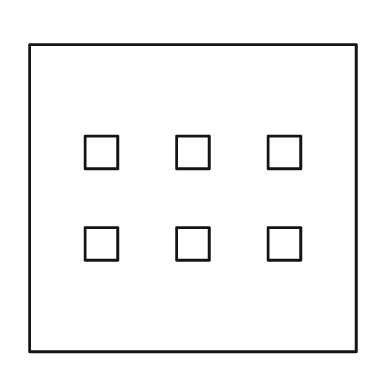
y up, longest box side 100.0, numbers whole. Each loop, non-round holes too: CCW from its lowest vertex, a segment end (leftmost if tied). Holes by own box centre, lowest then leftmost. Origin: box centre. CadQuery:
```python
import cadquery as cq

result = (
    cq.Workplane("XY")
    .moveTo(-50.0, -47.0)
    .lineTo(50.0, -47.0)
    .lineTo(50.0, 47.0)
    .lineTo(-50.0, 47.0)
    .close()
    .moveTo(-33.0, -19.0)
    .lineTo(-23.0, -19.0)
    .lineTo(-23.0, -9.0)
    .lineTo(-33.0, -9.0)
    .close()
    .moveTo(-5.0, -19.0)
    .lineTo(5.0, -19.0)
    .lineTo(5.0, -9.0)
    .lineTo(-5.0, -9.0)
    .close()
    .moveTo(23.0, -19.0)
    .lineTo(33.0, -19.0)
    .lineTo(33.0, -9.0)
    .lineTo(23.0, -9.0)
    .close()
    .moveTo(-33.0, 9.0)
    .lineTo(-23.0, 9.0)
    .lineTo(-23.0, 19.0)
    .lineTo(-33.0, 19.0)
    .close()
    .moveTo(-5.0, 9.0)
    .lineTo(5.0, 9.0)
    .lineTo(5.0, 19.0)
    .lineTo(-5.0, 19.0)
    .close()
    .moveTo(23.0, 9.0)
    .lineTo(33.0, 9.0)
    .lineTo(33.0, 19.0)
    .lineTo(23.0, 19.0)
    .close()
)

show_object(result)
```